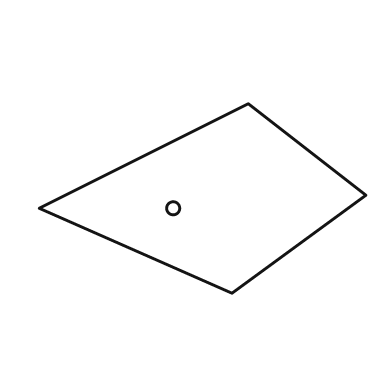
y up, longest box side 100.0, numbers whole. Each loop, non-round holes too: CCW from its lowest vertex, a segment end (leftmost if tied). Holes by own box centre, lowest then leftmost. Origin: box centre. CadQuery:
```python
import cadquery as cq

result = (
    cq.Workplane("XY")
    .moveTo(9.0, -29.0)
    .lineTo(50.0, 1.0)
    .lineTo(14.0, 29.0)
    .lineTo(-50.0, -3.0)
    .close()
    .moveTo(-9.0, -3.0)
    .circle(2.0)
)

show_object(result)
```